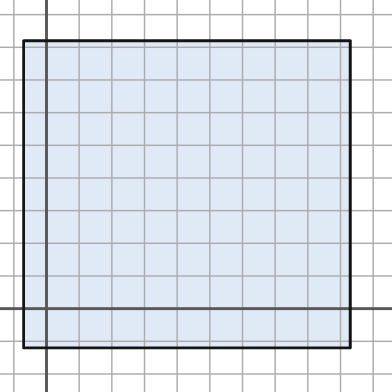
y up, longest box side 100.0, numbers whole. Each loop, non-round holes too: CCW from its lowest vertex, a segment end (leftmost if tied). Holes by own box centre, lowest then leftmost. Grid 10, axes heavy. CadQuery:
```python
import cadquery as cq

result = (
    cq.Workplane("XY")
    .moveTo(-7.0, -12.0)
    .lineTo(93.0, -12.0)
    .lineTo(93.0, 82.0)
    .lineTo(-7.0, 82.0)
    .close()
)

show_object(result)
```